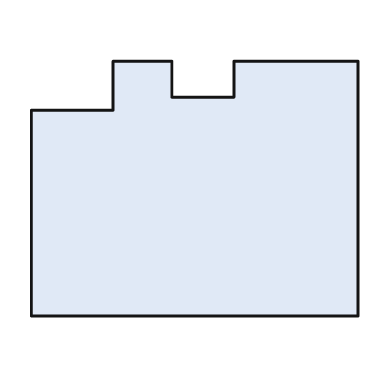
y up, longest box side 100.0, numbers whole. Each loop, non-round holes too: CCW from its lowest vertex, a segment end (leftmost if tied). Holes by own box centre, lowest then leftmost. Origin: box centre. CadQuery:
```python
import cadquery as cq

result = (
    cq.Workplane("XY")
    .moveTo(-50.0, -39.0)
    .lineTo(50.0, -39.0)
    .lineTo(50.0, 39.0)
    .lineTo(12.0, 39.0)
    .lineTo(12.0, 28.0)
    .lineTo(-7.0, 28.0)
    .lineTo(-7.0, 39.0)
    .lineTo(-25.0, 39.0)
    .lineTo(-25.0, 24.0)
    .lineTo(-50.0, 24.0)
    .close()
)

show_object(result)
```